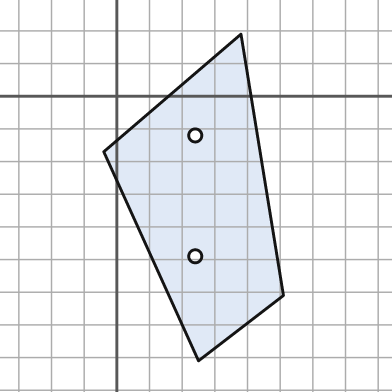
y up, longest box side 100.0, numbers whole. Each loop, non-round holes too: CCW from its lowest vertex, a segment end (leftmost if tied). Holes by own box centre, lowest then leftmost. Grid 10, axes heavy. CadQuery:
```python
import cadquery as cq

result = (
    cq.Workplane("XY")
    .moveTo(25.0, -81.0)
    .lineTo(51.0, -61.0)
    .lineTo(38.0, 19.0)
    .lineTo(-4.0, -17.0)
    .close()
    .moveTo(24.0, -49.0)
    .circle(2.0)
    .moveTo(24.0, -12.0)
    .circle(2.0)
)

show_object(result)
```